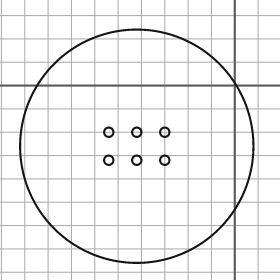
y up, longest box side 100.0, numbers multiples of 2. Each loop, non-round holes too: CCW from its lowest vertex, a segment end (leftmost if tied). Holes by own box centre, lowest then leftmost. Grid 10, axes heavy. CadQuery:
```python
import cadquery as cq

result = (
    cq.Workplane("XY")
    .moveTo(-42.0, -26.0)
    .circle(50.0)
    .moveTo(-54.0, -32.0)
    .circle(2.0)
    .moveTo(-42.0, -32.0)
    .circle(2.0)
    .moveTo(-30.0, -32.0)
    .circle(2.0)
    .moveTo(-54.0, -20.0)
    .circle(2.0)
    .moveTo(-42.0, -20.0)
    .circle(2.0)
    .moveTo(-30.0, -20.0)
    .circle(2.0)
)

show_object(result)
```